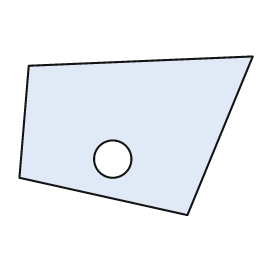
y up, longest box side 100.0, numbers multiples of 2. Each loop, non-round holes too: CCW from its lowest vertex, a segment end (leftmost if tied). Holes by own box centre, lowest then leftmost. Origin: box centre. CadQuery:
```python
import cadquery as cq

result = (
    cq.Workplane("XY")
    .moveTo(22.0, -34.0)
    .lineTo(50.0, 34.0)
    .lineTo(-46.0, 30.0)
    .lineTo(-50.0, -18.0)
    .close()
    .moveTo(-10.0, -10.0)
    .circle(8.0)
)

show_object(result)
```